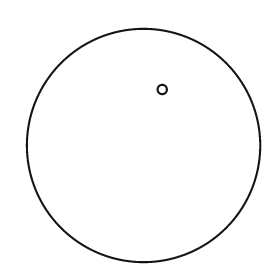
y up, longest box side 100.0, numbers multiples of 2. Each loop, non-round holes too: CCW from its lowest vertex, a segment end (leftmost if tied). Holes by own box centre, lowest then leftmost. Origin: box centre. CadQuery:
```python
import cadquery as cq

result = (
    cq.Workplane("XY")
    .moveTo(0.0, 0.0)
    .circle(50.0)
    .moveTo(8.0, 24.0)
    .circle(2.0)
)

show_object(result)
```